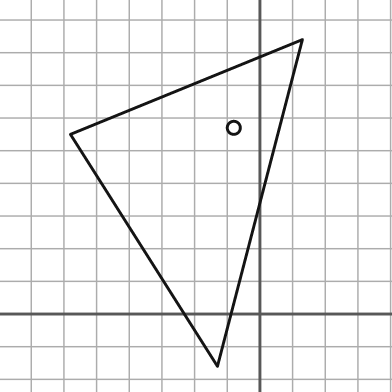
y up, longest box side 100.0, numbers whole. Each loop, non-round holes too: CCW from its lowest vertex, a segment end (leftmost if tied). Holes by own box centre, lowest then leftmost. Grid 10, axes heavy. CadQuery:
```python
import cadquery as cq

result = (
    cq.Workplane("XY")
    .moveTo(-13.0, -16.0)
    .lineTo(13.0, 84.0)
    .lineTo(-58.0, 55.0)
    .close()
    .moveTo(-8.0, 57.0)
    .circle(2.0)
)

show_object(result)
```